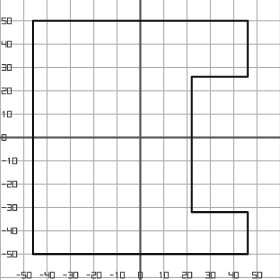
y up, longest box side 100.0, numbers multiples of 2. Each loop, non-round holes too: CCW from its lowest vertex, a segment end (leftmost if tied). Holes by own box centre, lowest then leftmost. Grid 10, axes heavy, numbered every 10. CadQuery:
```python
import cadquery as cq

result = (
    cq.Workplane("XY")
    .moveTo(-46.0, -50.0)
    .lineTo(46.0, -50.0)
    .lineTo(46.0, -32.0)
    .lineTo(22.0, -32.0)
    .lineTo(22.0, 26.0)
    .lineTo(46.0, 26.0)
    .lineTo(46.0, 50.0)
    .lineTo(-46.0, 50.0)
    .close()
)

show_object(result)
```